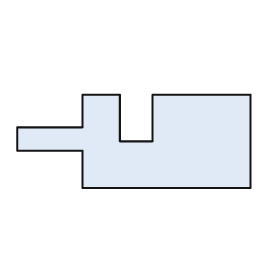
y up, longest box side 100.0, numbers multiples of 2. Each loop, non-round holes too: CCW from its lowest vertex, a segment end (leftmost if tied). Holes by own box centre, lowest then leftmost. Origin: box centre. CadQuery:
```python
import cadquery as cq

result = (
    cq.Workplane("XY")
    .moveTo(-22.0, -20.0)
    .lineTo(50.0, -20.0)
    .lineTo(50.0, 20.0)
    .lineTo(8.0, 20.0)
    .lineTo(8.0, 0.0)
    .lineTo(-6.0, 0.0)
    .lineTo(-6.0, 20.0)
    .lineTo(-22.0, 20.0)
    .lineTo(-22.0, 6.0)
    .lineTo(-50.0, 6.0)
    .lineTo(-50.0, -4.0)
    .lineTo(-22.0, -4.0)
    .close()
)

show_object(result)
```